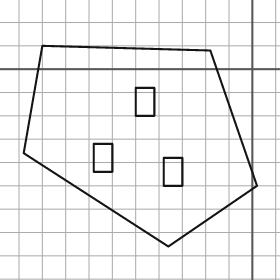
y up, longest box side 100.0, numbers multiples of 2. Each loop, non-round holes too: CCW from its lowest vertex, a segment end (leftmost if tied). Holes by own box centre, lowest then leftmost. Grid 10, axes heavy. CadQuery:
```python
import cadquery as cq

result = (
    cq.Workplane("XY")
    .moveTo(-36.0, -76.0)
    .lineTo(2.0, -50.0)
    .lineTo(-18.0, 8.0)
    .lineTo(-90.0, 10.0)
    .lineTo(-98.0, -36.0)
    .close()
    .moveTo(-38.0, -50.0)
    .lineTo(-30.0, -50.0)
    .lineTo(-30.0, -38.0)
    .lineTo(-38.0, -38.0)
    .close()
    .moveTo(-68.0, -44.0)
    .lineTo(-60.0, -44.0)
    .lineTo(-60.0, -32.0)
    .lineTo(-68.0, -32.0)
    .close()
    .moveTo(-50.0, -20.0)
    .lineTo(-42.0, -20.0)
    .lineTo(-42.0, -8.0)
    .lineTo(-50.0, -8.0)
    .close()
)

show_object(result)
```